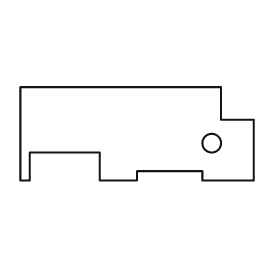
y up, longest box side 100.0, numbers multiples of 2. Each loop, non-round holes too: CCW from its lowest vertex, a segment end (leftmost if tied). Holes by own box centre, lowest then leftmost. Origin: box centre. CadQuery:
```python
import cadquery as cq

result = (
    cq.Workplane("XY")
    .moveTo(-50.0, -20.0)
    .lineTo(-46.0, -20.0)
    .lineTo(-46.0, -8.0)
    .lineTo(-16.0, -8.0)
    .lineTo(-16.0, -20.0)
    .lineTo(0.0, -20.0)
    .lineTo(0.0, -16.0)
    .lineTo(28.0, -16.0)
    .lineTo(28.0, -20.0)
    .lineTo(50.0, -20.0)
    .lineTo(50.0, 6.0)
    .lineTo(36.0, 6.0)
    .lineTo(36.0, 20.0)
    .lineTo(-50.0, 20.0)
    .close()
    .moveTo(32.0, -4.0)
    .circle(4.0)
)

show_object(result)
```